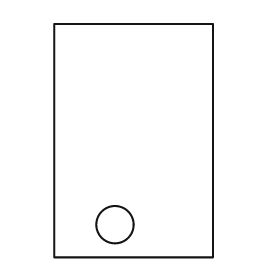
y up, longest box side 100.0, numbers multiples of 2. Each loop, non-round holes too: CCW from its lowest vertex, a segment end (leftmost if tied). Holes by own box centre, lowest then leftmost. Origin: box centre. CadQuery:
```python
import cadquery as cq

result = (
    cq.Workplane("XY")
    .moveTo(-34.0, -50.0)
    .lineTo(34.0, -50.0)
    .lineTo(34.0, 50.0)
    .lineTo(-34.0, 50.0)
    .close()
    .moveTo(-8.0, -36.0)
    .circle(8.0)
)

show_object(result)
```